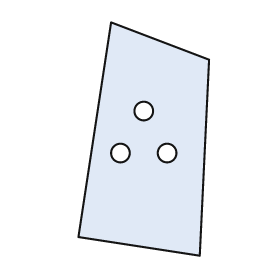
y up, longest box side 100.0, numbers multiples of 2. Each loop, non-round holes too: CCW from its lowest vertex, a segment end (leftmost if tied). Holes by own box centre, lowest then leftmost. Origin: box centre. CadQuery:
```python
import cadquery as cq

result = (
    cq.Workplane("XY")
    .moveTo(24.0, -50.0)
    .lineTo(28.0, 34.0)
    .lineTo(-14.0, 50.0)
    .lineTo(-28.0, -42.0)
    .close()
    .moveTo(-10.0, -6.0)
    .circle(4.0)
    .moveTo(10.0, -6.0)
    .circle(4.0)
    .moveTo(0.0, 12.0)
    .circle(4.0)
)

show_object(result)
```